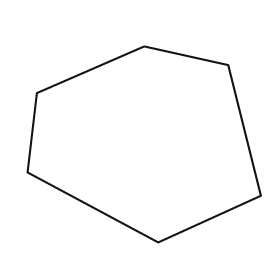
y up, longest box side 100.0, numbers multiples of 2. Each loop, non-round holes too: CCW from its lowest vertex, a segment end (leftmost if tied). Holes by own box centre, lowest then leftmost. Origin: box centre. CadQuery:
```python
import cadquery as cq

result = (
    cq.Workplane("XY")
    .moveTo(6.0, -42.0)
    .lineTo(50.0, -22.0)
    .lineTo(36.0, 34.0)
    .lineTo(0.0, 42.0)
    .lineTo(-46.0, 22.0)
    .lineTo(-50.0, -12.0)
    .close()
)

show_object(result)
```